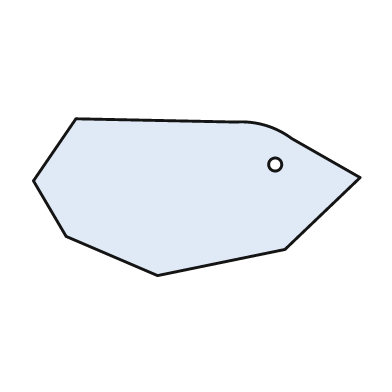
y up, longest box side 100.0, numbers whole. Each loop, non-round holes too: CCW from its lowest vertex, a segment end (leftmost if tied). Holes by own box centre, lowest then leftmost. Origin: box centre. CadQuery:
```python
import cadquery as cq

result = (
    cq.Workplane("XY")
    .moveTo(-12.0, -24.0)
    .lineTo(27.0, -16.0)
    .lineTo(50.0, 6.0)
    .lineTo(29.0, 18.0)
    .threePointArc((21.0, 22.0), (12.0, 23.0))
    .lineTo(-37.0, 24.0)
    .lineTo(-50.0, 5.0)
    .lineTo(-40.0, -12.0)
    .close()
    .moveTo(24.0, 10.0)
    .circle(2.0)
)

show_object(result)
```